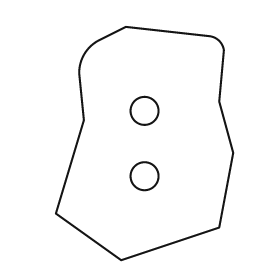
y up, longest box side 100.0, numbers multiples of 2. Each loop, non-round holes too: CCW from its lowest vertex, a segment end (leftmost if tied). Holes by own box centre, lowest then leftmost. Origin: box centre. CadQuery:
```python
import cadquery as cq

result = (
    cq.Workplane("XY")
    .moveTo(-10.0, -50.0)
    .lineTo(32.0, -36.0)
    .lineTo(38.0, -4.0)
    .lineTo(32.0, 18.0)
    .lineTo(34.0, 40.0)
    .threePointArc((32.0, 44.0), (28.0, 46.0))
    .lineTo(-8.0, 50.0)
    .lineTo(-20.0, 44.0)
    .threePointArc((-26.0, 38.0), (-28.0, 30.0))
    .lineTo(-26.0, 10.0)
    .lineTo(-38.0, -30.0)
    .close()
    .moveTo(0.0, -14.0)
    .circle(6.0)
    .moveTo(0.0, 14.0)
    .circle(6.0)
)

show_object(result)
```